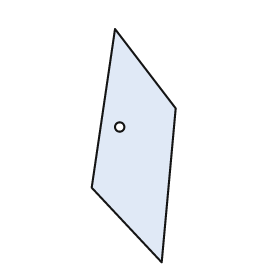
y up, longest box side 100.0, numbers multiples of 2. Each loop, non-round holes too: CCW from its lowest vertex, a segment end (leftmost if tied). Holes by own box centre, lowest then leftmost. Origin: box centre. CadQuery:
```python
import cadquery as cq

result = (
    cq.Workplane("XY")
    .moveTo(12.0, -50.0)
    .lineTo(18.0, 16.0)
    .lineTo(-8.0, 50.0)
    .lineTo(-18.0, -18.0)
    .close()
    .moveTo(-6.0, 8.0)
    .circle(2.0)
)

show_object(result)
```